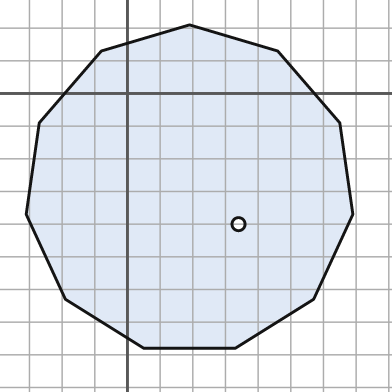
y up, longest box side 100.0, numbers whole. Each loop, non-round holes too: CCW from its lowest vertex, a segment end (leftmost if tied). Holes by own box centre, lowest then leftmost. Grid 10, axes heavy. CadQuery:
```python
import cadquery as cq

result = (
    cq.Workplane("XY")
    .moveTo(5.0, -78.0)
    .lineTo(33.0, -78.0)
    .lineTo(57.0, -63.0)
    .lineTo(69.0, -37.0)
    .lineTo(65.0, -9.0)
    .lineTo(46.0, 13.0)
    .lineTo(19.0, 21.0)
    .lineTo(-8.0, 13.0)
    .lineTo(-27.0, -9.0)
    .lineTo(-31.0, -37.0)
    .lineTo(-19.0, -63.0)
    .close()
    .moveTo(34.0, -40.0)
    .circle(2.0)
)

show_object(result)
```